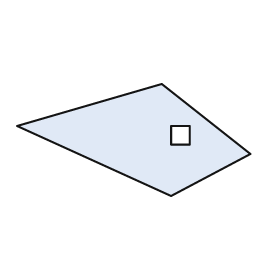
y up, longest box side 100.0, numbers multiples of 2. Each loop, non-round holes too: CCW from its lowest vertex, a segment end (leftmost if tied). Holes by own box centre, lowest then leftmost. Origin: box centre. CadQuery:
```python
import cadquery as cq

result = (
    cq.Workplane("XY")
    .moveTo(16.0, -24.0)
    .lineTo(50.0, -6.0)
    .lineTo(12.0, 24.0)
    .lineTo(-50.0, 6.0)
    .close()
    .moveTo(16.0, -2.0)
    .lineTo(24.0, -2.0)
    .lineTo(24.0, 6.0)
    .lineTo(16.0, 6.0)
    .close()
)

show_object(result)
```